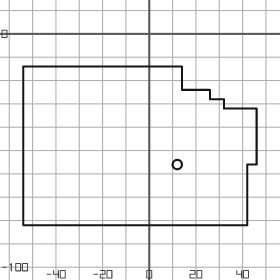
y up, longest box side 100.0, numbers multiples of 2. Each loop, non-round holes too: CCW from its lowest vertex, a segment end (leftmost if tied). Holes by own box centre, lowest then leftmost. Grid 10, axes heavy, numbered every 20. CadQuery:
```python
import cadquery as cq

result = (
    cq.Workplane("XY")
    .moveTo(-54.0, -82.0)
    .lineTo(42.0, -82.0)
    .lineTo(42.0, -56.0)
    .lineTo(46.0, -56.0)
    .lineTo(46.0, -32.0)
    .lineTo(32.0, -32.0)
    .lineTo(32.0, -28.0)
    .lineTo(26.0, -28.0)
    .lineTo(26.0, -24.0)
    .lineTo(14.0, -24.0)
    .lineTo(14.0, -14.0)
    .lineTo(-54.0, -14.0)
    .close()
    .moveTo(12.0, -56.0)
    .circle(2.0)
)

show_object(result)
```